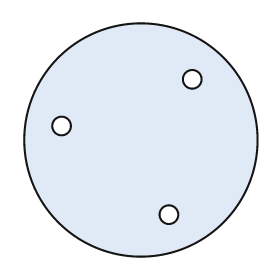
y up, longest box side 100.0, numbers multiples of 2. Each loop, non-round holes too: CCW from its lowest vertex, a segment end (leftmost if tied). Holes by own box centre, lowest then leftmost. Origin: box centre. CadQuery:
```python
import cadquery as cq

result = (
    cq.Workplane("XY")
    .moveTo(0.0, 0.0)
    .circle(50.0)
    .moveTo(12.0, -32.0)
    .circle(4.0)
    .moveTo(-34.0, 6.0)
    .circle(4.0)
    .moveTo(22.0, 26.0)
    .circle(4.0)
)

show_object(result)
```